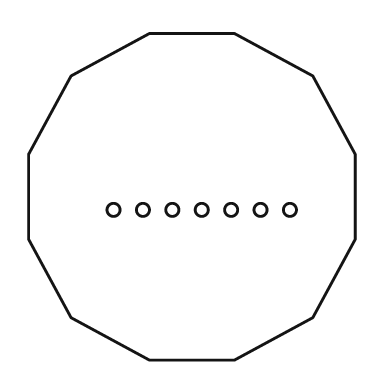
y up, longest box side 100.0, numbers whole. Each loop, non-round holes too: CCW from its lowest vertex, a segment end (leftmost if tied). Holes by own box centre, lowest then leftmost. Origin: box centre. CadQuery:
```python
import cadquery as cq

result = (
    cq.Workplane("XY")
    .moveTo(-13.0, -50.0)
    .lineTo(13.0, -50.0)
    .lineTo(37.0, -37.0)
    .lineTo(50.0, -13.0)
    .lineTo(50.0, 13.0)
    .lineTo(37.0, 37.0)
    .lineTo(13.0, 50.0)
    .lineTo(-13.0, 50.0)
    .lineTo(-37.0, 37.0)
    .lineTo(-50.0, 13.0)
    .lineTo(-50.0, -13.0)
    .lineTo(-37.0, -37.0)
    .close()
    .moveTo(-24.0, -4.0)
    .circle(2.0)
    .moveTo(-15.0, -4.0)
    .circle(2.0)
    .moveTo(-6.0, -4.0)
    .circle(2.0)
    .moveTo(3.0, -4.0)
    .circle(2.0)
    .moveTo(12.0, -4.0)
    .circle(2.0)
    .moveTo(21.0, -4.0)
    .circle(2.0)
    .moveTo(30.0, -4.0)
    .circle(2.0)
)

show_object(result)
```